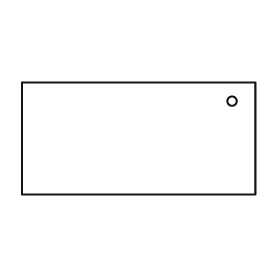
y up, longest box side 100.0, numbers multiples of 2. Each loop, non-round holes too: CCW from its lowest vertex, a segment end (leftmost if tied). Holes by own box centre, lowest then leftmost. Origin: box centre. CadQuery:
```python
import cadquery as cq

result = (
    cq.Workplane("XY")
    .moveTo(-50.0, -24.0)
    .lineTo(50.0, -24.0)
    .lineTo(50.0, 24.0)
    .lineTo(-50.0, 24.0)
    .close()
    .moveTo(40.0, 16.0)
    .circle(2.0)
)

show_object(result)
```